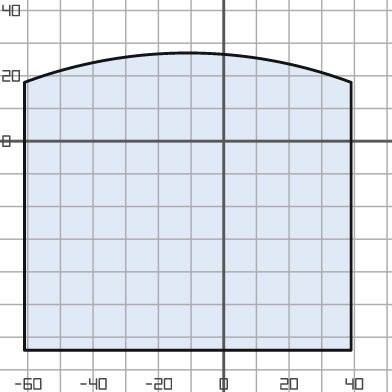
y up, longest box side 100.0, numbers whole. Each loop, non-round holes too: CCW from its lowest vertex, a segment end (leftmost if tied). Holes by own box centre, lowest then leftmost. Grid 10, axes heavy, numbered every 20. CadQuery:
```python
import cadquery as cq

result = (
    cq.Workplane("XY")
    .moveTo(-61.0, -64.0)
    .lineTo(39.0, -64.0)
    .lineTo(39.0, 18.0)
    .threePointArc((-11.0, 27.0), (-61.0, 18.0))
    .close()
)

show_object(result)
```